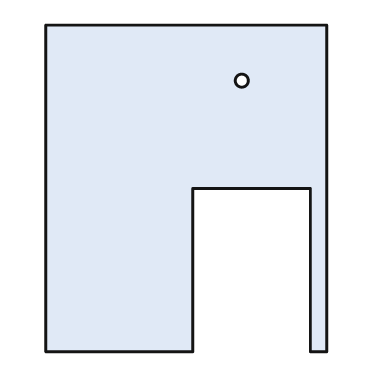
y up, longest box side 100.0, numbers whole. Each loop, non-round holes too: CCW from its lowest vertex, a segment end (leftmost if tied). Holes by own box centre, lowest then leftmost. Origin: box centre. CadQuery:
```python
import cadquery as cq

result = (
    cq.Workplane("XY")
    .moveTo(-43.0, -50.0)
    .lineTo(2.0, -50.0)
    .lineTo(2.0, 0.0)
    .lineTo(38.0, 0.0)
    .lineTo(38.0, -50.0)
    .lineTo(43.0, -50.0)
    .lineTo(43.0, 50.0)
    .lineTo(-43.0, 50.0)
    .close()
    .moveTo(17.0, 33.0)
    .circle(2.0)
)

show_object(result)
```